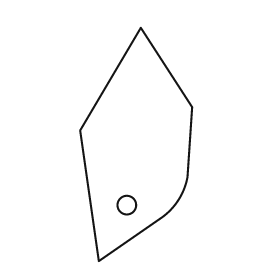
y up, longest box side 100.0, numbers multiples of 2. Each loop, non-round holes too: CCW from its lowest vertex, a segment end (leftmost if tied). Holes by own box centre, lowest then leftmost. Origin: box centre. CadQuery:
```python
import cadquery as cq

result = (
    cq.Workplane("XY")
    .moveTo(-16.0, -50.0)
    .lineTo(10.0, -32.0)
    .threePointArc((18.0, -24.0), (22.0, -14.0))
    .lineTo(24.0, 16.0)
    .lineTo(2.0, 50.0)
    .lineTo(-24.0, 6.0)
    .close()
    .moveTo(-4.0, -26.0)
    .circle(4.0)
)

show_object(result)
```